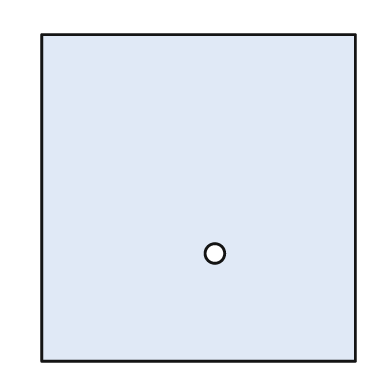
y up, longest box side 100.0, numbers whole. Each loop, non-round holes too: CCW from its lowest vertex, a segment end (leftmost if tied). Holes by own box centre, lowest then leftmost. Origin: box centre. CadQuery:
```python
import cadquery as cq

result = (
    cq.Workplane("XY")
    .moveTo(-48.0, -50.0)
    .lineTo(48.0, -50.0)
    .lineTo(48.0, 50.0)
    .lineTo(-48.0, 50.0)
    .close()
    .moveTo(5.0, -17.0)
    .circle(3.0)
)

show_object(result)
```